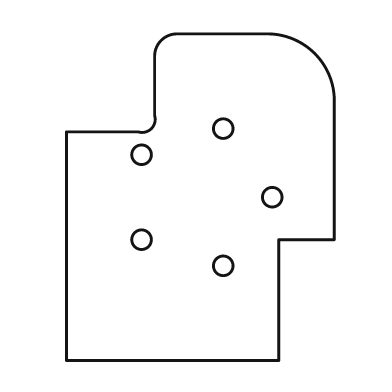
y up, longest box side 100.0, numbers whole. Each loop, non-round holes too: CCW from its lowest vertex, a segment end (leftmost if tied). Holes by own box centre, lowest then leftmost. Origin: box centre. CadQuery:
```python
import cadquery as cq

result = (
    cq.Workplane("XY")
    .moveTo(-41.0, -50.0)
    .lineTo(24.0, -50.0)
    .lineTo(24.0, -13.0)
    .lineTo(41.0, -13.0)
    .lineTo(41.0, 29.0)
    .threePointArc((35.0, 44.0), (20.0, 50.0))
    .lineTo(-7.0, 50.0)
    .threePointArc((-12.0, 48.0), (-14.0, 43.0))
    .lineTo(-14.0, 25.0)
    .threePointArc((-15.0, 21.0), (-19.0, 20.0))
    .lineTo(-41.0, 20.0)
    .close()
    .moveTo(7.0, -21.0)
    .circle(3.0)
    .moveTo(-18.0, -13.0)
    .circle(3.0)
    .moveTo(22.0, 0.0)
    .circle(3.0)
    .moveTo(-18.0, 13.0)
    .circle(3.0)
    .moveTo(7.0, 21.0)
    .circle(3.0)
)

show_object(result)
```